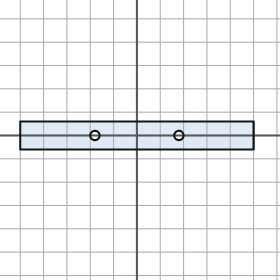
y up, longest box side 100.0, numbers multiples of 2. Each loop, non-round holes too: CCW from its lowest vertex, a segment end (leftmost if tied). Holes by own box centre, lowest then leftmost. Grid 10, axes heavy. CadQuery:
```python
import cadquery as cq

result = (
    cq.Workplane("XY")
    .moveTo(-50.0, -6.0)
    .lineTo(50.0, -6.0)
    .lineTo(50.0, 6.0)
    .lineTo(-50.0, 6.0)
    .close()
    .moveTo(-18.0, 0.0)
    .circle(2.0)
    .moveTo(18.0, 0.0)
    .circle(2.0)
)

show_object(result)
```